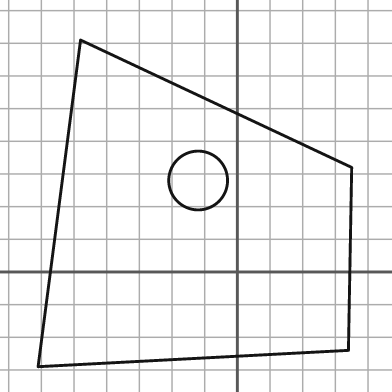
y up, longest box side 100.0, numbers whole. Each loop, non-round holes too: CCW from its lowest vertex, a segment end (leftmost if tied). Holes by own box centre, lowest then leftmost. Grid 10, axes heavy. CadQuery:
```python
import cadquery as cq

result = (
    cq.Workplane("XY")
    .moveTo(-61.0, -29.0)
    .lineTo(34.0, -24.0)
    .lineTo(35.0, 32.0)
    .lineTo(-48.0, 71.0)
    .close()
    .moveTo(-12.0, 28.0)
    .circle(9.0)
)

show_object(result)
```